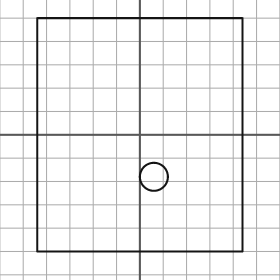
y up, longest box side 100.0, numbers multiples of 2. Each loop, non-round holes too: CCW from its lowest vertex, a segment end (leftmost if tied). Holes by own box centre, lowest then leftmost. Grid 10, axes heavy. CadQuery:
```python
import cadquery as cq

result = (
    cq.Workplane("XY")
    .moveTo(-44.0, -50.0)
    .lineTo(44.0, -50.0)
    .lineTo(44.0, 50.0)
    .lineTo(-44.0, 50.0)
    .close()
    .moveTo(6.0, -18.0)
    .circle(6.0)
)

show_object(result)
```